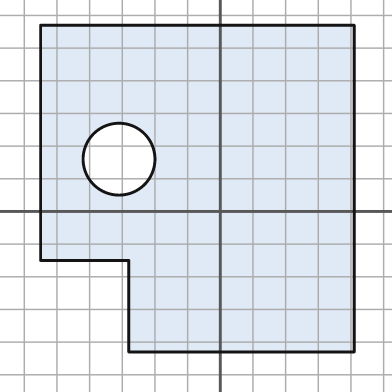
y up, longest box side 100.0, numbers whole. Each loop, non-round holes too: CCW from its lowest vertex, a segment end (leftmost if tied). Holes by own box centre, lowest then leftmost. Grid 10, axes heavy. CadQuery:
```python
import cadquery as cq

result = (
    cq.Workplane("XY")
    .moveTo(-28.0, -43.0)
    .lineTo(41.0, -43.0)
    .lineTo(41.0, 57.0)
    .lineTo(-55.0, 57.0)
    .lineTo(-55.0, -15.0)
    .lineTo(-28.0, -15.0)
    .close()
    .moveTo(-31.0, 16.0)
    .circle(11.0)
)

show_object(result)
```